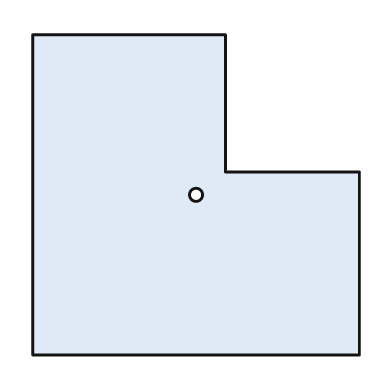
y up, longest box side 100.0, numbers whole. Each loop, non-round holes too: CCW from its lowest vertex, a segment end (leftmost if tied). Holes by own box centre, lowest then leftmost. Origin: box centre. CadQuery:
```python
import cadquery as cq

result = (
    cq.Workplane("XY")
    .moveTo(-50.0, -49.0)
    .lineTo(50.0, -49.0)
    .lineTo(50.0, 7.0)
    .lineTo(9.0, 7.0)
    .lineTo(9.0, 49.0)
    .lineTo(-50.0, 49.0)
    .close()
    .moveTo(0.0, 0.0)
    .circle(2.0)
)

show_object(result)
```